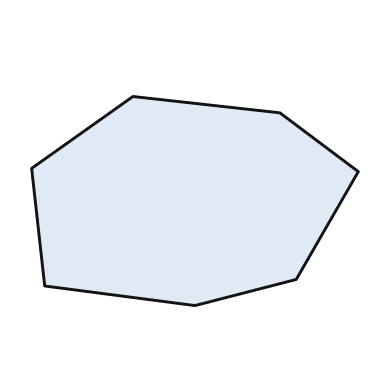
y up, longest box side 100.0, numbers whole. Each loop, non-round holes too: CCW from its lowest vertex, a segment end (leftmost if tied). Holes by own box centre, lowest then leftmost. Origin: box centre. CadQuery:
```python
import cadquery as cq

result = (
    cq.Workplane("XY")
    .moveTo(0.0, -32.0)
    .lineTo(31.0, -24.0)
    .lineTo(50.0, 9.0)
    .lineTo(26.0, 27.0)
    .lineTo(-19.0, 32.0)
    .lineTo(-50.0, 10.0)
    .lineTo(-46.0, -26.0)
    .close()
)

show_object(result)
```